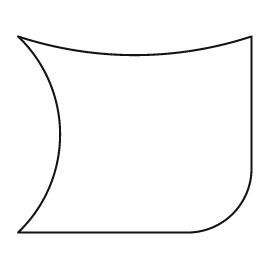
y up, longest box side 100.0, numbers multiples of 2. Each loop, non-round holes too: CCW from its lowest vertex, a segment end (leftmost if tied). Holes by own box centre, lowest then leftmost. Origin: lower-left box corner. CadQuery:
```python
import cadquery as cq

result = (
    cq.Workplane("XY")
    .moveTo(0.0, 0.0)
    .lineTo(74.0, 0.0)
    .threePointArc((92.0, 8.0), (100.0, 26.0))
    .lineTo(100.0, 84.0)
    .threePointArc((50.0, 76.0), (0.0, 84.0))
    .threePointArc((18.0, 42.0), (0.0, 0.0))
    .close()
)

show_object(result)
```